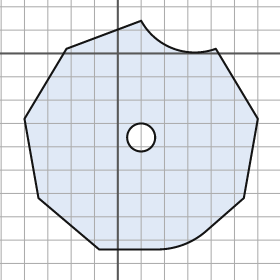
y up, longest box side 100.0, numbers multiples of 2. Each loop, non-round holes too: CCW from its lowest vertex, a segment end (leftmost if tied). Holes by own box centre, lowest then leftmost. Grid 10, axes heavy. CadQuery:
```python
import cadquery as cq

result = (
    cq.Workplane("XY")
    .moveTo(-8.0, -84.0)
    .lineTo(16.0, -84.0)
    .threePointArc((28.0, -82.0), (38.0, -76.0))
    .lineTo(54.0, -62.0)
    .lineTo(60.0, -28.0)
    .lineTo(42.0, 2.0)
    .threePointArc((24.0, 2.0), (10.0, 14.0))
    .lineTo(-22.0, 2.0)
    .lineTo(-40.0, -28.0)
    .lineTo(-34.0, -62.0)
    .close()
    .moveTo(10.0, -36.0)
    .circle(6.0)
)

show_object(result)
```